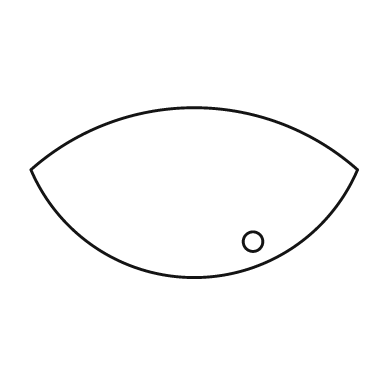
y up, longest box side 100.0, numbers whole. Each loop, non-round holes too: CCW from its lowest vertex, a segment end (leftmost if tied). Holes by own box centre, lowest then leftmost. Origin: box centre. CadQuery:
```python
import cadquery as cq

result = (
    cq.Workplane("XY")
    .moveTo(-50.0, 7.0)
    .threePointArc((0.0, -26.0), (50.0, 7.0))
    .threePointArc((0.0, 26.0), (-50.0, 7.0))
    .close()
    .moveTo(18.0, -15.0)
    .circle(3.0)
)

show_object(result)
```